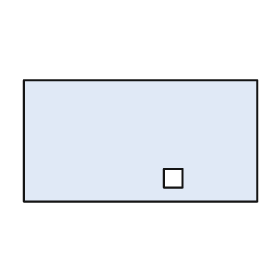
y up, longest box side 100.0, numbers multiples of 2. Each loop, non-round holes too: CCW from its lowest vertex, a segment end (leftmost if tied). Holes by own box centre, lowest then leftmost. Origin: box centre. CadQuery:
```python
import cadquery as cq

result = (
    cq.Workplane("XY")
    .moveTo(-50.0, -26.0)
    .lineTo(50.0, -26.0)
    .lineTo(50.0, 26.0)
    .lineTo(-50.0, 26.0)
    .close()
    .moveTo(10.0, -20.0)
    .lineTo(18.0, -20.0)
    .lineTo(18.0, -12.0)
    .lineTo(10.0, -12.0)
    .close()
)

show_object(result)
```